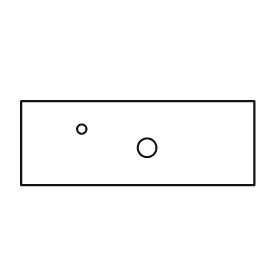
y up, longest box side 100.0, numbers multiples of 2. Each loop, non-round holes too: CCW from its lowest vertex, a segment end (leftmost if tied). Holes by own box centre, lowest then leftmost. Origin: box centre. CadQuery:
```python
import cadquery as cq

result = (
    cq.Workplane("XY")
    .moveTo(-50.0, -18.0)
    .lineTo(50.0, -18.0)
    .lineTo(50.0, 18.0)
    .lineTo(-50.0, 18.0)
    .close()
    .moveTo(4.0, -2.0)
    .circle(4.0)
    .moveTo(-24.0, 6.0)
    .circle(2.0)
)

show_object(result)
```